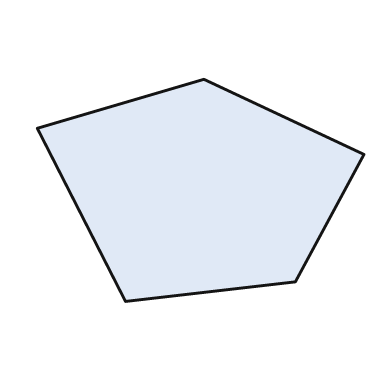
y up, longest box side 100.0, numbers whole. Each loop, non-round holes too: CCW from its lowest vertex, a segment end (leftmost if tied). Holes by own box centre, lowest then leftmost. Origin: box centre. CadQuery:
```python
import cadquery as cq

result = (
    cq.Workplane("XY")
    .moveTo(-23.0, -34.0)
    .lineTo(29.0, -28.0)
    .lineTo(50.0, 11.0)
    .lineTo(1.0, 34.0)
    .lineTo(-50.0, 19.0)
    .close()
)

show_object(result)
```